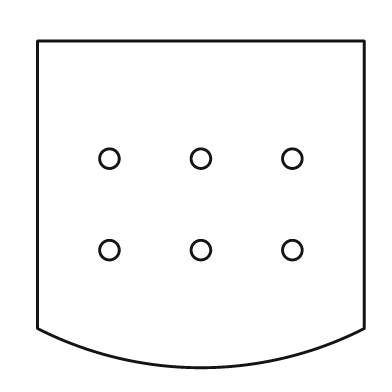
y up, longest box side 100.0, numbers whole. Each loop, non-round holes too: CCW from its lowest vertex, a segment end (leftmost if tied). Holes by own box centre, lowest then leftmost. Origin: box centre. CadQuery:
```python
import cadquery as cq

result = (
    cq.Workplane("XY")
    .moveTo(-50.0, -38.0)
    .threePointArc((0.0, -50.0), (50.0, -38.0))
    .lineTo(50.0, 50.0)
    .lineTo(-50.0, 50.0)
    .close()
    .moveTo(-28.0, -14.0)
    .circle(3.0)
    .moveTo(0.0, -14.0)
    .circle(3.0)
    .moveTo(28.0, -14.0)
    .circle(3.0)
    .moveTo(-28.0, 14.0)
    .circle(3.0)
    .moveTo(0.0, 14.0)
    .circle(3.0)
    .moveTo(28.0, 14.0)
    .circle(3.0)
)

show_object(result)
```